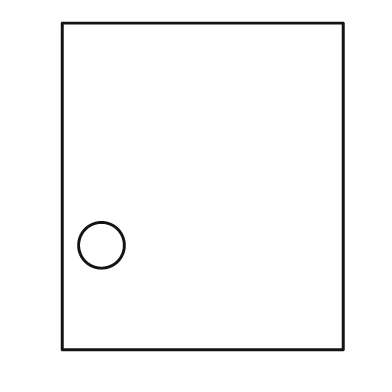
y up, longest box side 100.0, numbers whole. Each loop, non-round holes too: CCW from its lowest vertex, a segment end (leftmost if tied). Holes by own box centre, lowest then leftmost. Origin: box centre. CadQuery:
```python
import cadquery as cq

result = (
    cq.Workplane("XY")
    .moveTo(-43.0, -50.0)
    .lineTo(43.0, -50.0)
    .lineTo(43.0, 50.0)
    .lineTo(-43.0, 50.0)
    .close()
    .moveTo(-31.0, -18.0)
    .circle(7.0)
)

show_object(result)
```